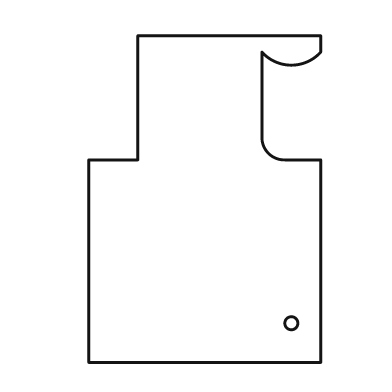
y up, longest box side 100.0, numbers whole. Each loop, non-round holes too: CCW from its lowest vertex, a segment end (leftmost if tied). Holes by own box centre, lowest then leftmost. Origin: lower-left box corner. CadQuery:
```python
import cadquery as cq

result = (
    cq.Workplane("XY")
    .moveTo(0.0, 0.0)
    .lineTo(71.0, 0.0)
    .lineTo(71.0, 62.0)
    .lineTo(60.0, 62.0)
    .threePointArc((55.0, 64.0), (53.0, 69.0))
    .lineTo(53.0, 95.0)
    .threePointArc((62.0, 91.0), (71.0, 95.0))
    .lineTo(71.0, 100.0)
    .lineTo(15.0, 100.0)
    .lineTo(15.0, 62.0)
    .lineTo(0.0, 62.0)
    .close()
    .moveTo(62.0, 12.0)
    .circle(2.0)
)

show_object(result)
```